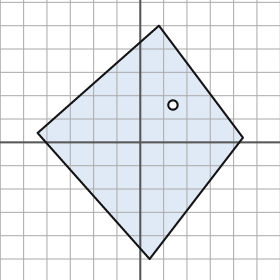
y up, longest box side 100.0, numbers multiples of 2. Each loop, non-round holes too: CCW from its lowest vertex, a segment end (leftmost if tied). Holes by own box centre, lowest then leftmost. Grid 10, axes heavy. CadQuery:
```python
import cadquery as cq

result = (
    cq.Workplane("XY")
    .moveTo(4.0, -50.0)
    .lineTo(44.0, 2.0)
    .lineTo(8.0, 50.0)
    .lineTo(-44.0, 4.0)
    .close()
    .moveTo(14.0, 16.0)
    .circle(2.0)
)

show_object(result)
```